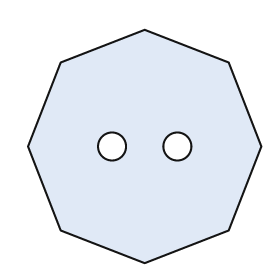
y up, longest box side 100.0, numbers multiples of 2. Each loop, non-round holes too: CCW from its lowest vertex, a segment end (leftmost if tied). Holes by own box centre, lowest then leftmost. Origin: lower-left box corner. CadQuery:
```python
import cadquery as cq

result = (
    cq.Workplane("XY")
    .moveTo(50.0, 0.0)
    .lineTo(86.0, 14.0)
    .lineTo(100.0, 50.0)
    .lineTo(86.0, 86.0)
    .lineTo(50.0, 100.0)
    .lineTo(14.0, 86.0)
    .lineTo(0.0, 50.0)
    .lineTo(14.0, 14.0)
    .close()
    .moveTo(36.0, 50.0)
    .circle(6.0)
    .moveTo(64.0, 50.0)
    .circle(6.0)
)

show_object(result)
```